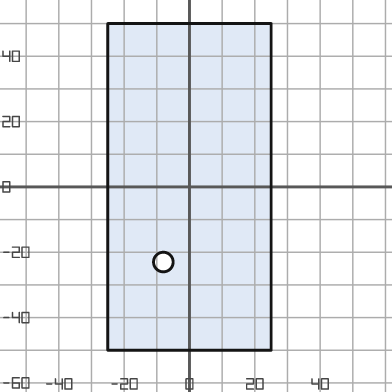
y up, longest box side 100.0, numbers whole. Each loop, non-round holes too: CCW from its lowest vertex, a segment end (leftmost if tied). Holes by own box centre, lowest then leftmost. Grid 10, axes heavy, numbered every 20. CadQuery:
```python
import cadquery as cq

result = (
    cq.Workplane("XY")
    .moveTo(-25.0, -50.0)
    .lineTo(25.0, -50.0)
    .lineTo(25.0, 50.0)
    .lineTo(-25.0, 50.0)
    .close()
    .moveTo(-8.0, -23.0)
    .circle(3.0)
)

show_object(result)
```